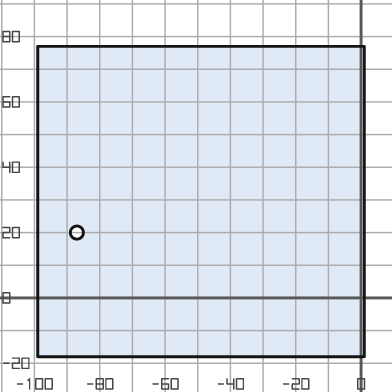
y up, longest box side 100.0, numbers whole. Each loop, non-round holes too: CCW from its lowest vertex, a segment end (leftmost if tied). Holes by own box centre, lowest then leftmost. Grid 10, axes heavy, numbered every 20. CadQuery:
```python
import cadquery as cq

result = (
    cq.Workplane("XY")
    .moveTo(-99.0, -18.0)
    .lineTo(1.0, -18.0)
    .lineTo(1.0, 77.0)
    .lineTo(-99.0, 77.0)
    .close()
    .moveTo(-87.0, 20.0)
    .circle(2.0)
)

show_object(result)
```